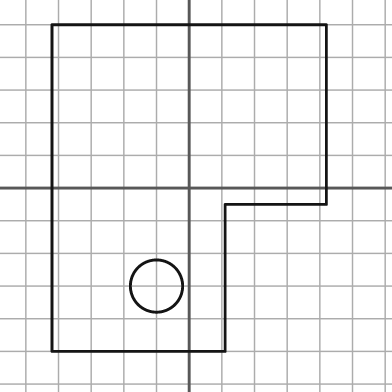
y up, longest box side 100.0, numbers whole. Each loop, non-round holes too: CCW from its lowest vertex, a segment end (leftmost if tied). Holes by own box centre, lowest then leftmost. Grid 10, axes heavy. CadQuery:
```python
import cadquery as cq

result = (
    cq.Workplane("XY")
    .moveTo(-42.0, -50.0)
    .lineTo(11.0, -50.0)
    .lineTo(11.0, -5.0)
    .lineTo(42.0, -5.0)
    .lineTo(42.0, 50.0)
    .lineTo(-42.0, 50.0)
    .close()
    .moveTo(-10.0, -30.0)
    .circle(8.0)
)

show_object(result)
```